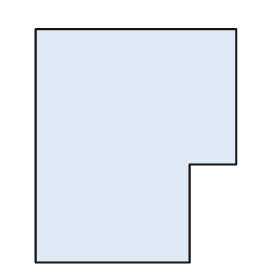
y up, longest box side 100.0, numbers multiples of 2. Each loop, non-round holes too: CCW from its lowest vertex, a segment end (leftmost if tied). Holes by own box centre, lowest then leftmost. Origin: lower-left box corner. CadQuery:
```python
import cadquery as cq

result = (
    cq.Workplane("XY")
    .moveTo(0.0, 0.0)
    .lineTo(66.0, 0.0)
    .lineTo(66.0, 42.0)
    .lineTo(86.0, 42.0)
    .lineTo(86.0, 100.0)
    .lineTo(0.0, 100.0)
    .close()
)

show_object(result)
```